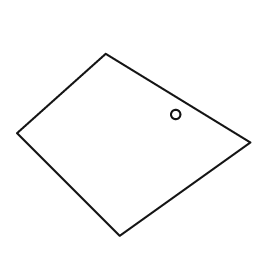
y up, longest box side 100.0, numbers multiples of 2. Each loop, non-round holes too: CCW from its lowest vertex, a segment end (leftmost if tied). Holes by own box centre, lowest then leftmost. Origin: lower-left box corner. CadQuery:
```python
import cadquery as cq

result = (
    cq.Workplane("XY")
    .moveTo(44.0, 0.0)
    .lineTo(100.0, 40.0)
    .lineTo(38.0, 78.0)
    .lineTo(0.0, 44.0)
    .close()
    .moveTo(68.0, 52.0)
    .circle(2.0)
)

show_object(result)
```